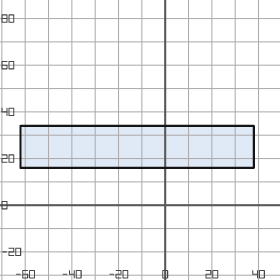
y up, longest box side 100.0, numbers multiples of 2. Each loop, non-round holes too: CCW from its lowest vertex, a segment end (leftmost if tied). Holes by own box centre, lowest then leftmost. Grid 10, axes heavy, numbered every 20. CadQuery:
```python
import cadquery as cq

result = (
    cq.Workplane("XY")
    .moveTo(-62.0, 16.0)
    .lineTo(38.0, 16.0)
    .lineTo(38.0, 34.0)
    .lineTo(-62.0, 34.0)
    .close()
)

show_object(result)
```